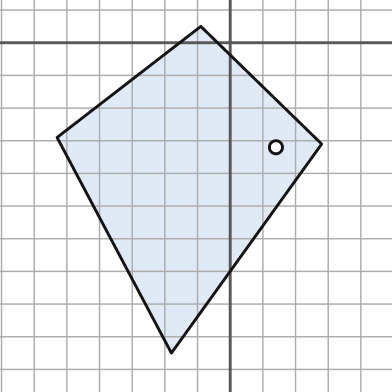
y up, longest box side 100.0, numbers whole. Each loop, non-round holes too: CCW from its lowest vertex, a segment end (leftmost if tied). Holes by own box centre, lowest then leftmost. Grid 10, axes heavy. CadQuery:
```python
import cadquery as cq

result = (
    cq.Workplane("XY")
    .moveTo(-18.0, -95.0)
    .lineTo(28.0, -31.0)
    .lineTo(-9.0, 5.0)
    .lineTo(-53.0, -29.0)
    .close()
    .moveTo(14.0, -32.0)
    .circle(2.0)
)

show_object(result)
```